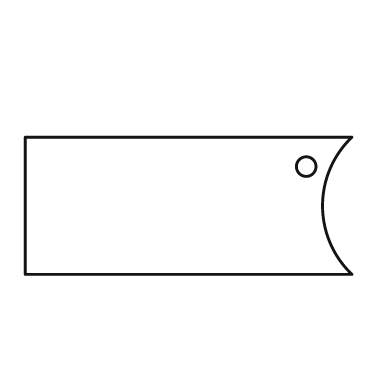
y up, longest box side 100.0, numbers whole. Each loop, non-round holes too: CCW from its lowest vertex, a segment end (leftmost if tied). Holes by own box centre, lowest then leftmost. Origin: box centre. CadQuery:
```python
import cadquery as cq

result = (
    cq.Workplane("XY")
    .moveTo(-50.0, -21.0)
    .lineTo(50.0, -21.0)
    .threePointArc((41.0, 0.0), (50.0, 21.0))
    .lineTo(-50.0, 21.0)
    .close()
    .moveTo(36.0, 12.0)
    .circle(3.0)
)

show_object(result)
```